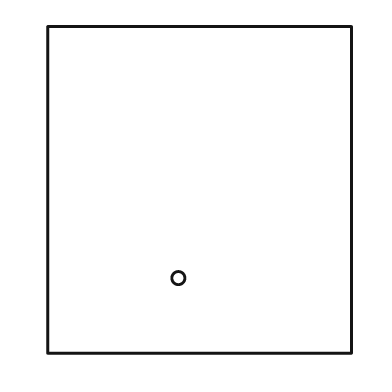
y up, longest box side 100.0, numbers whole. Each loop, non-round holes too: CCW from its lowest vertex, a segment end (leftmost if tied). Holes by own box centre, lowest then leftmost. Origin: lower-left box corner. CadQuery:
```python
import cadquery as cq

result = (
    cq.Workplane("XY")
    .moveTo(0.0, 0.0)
    .lineTo(93.0, 0.0)
    .lineTo(93.0, 100.0)
    .lineTo(0.0, 100.0)
    .close()
    .moveTo(40.0, 23.0)
    .circle(2.0)
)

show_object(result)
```